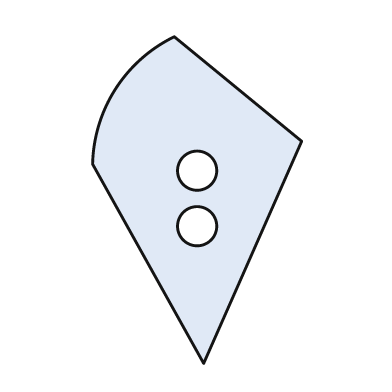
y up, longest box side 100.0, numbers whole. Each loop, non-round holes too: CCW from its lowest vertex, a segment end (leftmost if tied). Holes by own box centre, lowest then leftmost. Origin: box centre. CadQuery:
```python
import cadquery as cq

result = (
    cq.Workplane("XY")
    .moveTo(2.0, -50.0)
    .lineTo(32.0, 18.0)
    .lineTo(-7.0, 50.0)
    .threePointArc((-25.0, 34.0), (-32.0, 11.0))
    .close()
    .moveTo(0.0, -8.0)
    .circle(6.0)
    .moveTo(0.0, 9.0)
    .circle(6.0)
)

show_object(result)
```